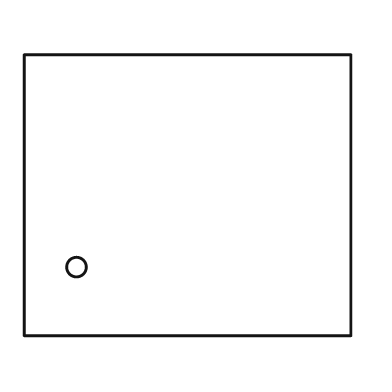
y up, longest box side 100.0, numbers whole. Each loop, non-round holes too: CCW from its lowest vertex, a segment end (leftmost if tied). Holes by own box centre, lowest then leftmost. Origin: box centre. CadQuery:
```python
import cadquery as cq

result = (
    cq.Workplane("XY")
    .moveTo(-50.0, -43.0)
    .lineTo(50.0, -43.0)
    .lineTo(50.0, 43.0)
    .lineTo(-50.0, 43.0)
    .close()
    .moveTo(-34.0, -22.0)
    .circle(3.0)
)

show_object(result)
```